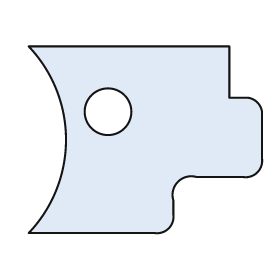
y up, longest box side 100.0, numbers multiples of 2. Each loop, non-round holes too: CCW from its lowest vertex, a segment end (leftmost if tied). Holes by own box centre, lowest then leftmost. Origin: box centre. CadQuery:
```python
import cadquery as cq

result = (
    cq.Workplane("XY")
    .moveTo(-50.0, -40.0)
    .lineTo(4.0, -40.0)
    .threePointArc((10.0, -38.0), (12.0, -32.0))
    .lineTo(12.0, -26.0)
    .threePointArc((14.0, -18.0), (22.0, -16.0))
    .lineTo(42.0, -16.0)
    .threePointArc((48.0, -14.0), (50.0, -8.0))
    .lineTo(50.0, 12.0)
    .threePointArc((48.0, 16.0), (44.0, 18.0))
    .lineTo(36.0, 18.0)
    .lineTo(36.0, 40.0)
    .lineTo(-50.0, 40.0)
    .threePointArc((-34.0, 0.0), (-50.0, -40.0))
    .close()
    .moveTo(-16.0, 12.0)
    .circle(10.0)
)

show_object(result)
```